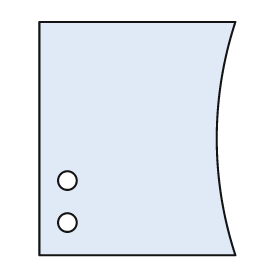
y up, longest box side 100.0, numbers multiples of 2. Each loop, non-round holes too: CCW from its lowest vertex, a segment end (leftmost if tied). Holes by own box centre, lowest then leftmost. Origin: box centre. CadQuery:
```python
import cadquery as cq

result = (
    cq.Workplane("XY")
    .moveTo(-42.0, -50.0)
    .lineTo(42.0, -50.0)
    .threePointArc((34.0, 0.0), (42.0, 50.0))
    .lineTo(-42.0, 50.0)
    .close()
    .moveTo(-30.0, -36.0)
    .circle(4.0)
    .moveTo(-30.0, -18.0)
    .circle(4.0)
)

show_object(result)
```